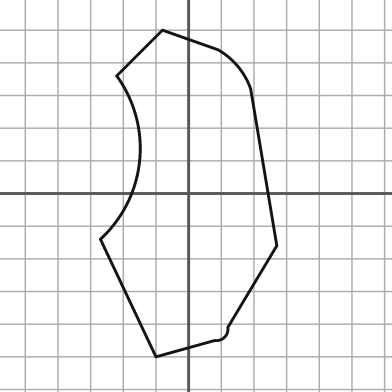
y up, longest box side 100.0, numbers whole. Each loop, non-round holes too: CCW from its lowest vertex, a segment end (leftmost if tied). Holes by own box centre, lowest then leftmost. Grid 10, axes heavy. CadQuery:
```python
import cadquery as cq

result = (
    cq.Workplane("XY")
    .moveTo(-10.0, -50.0)
    .lineTo(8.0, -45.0)
    .threePointArc((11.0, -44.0), (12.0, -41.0))
    .lineTo(27.0, -16.0)
    .lineTo(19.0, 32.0)
    .threePointArc((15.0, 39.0), (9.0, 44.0))
    .lineTo(-8.0, 50.0)
    .lineTo(-22.0, 36.0)
    .threePointArc((-15.0, 10.0), (-27.0, -14.0))
    .close()
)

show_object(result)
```